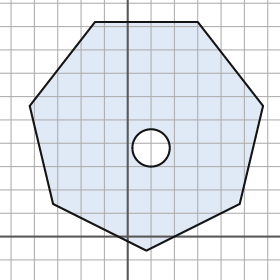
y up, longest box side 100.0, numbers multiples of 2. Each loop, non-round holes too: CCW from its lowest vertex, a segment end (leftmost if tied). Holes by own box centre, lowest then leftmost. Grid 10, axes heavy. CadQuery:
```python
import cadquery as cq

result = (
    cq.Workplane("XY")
    .moveTo(8.0, -6.0)
    .lineTo(48.0, 14.0)
    .lineTo(58.0, 56.0)
    .lineTo(30.0, 92.0)
    .lineTo(-14.0, 92.0)
    .lineTo(-42.0, 56.0)
    .lineTo(-32.0, 14.0)
    .close()
    .moveTo(10.0, 38.0)
    .circle(8.0)
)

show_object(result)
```